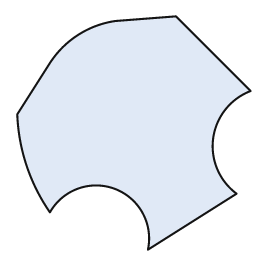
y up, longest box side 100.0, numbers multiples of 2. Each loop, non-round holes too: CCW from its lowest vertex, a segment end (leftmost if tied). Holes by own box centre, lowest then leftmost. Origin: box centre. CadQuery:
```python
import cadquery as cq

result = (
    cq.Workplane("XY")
    .moveTo(6.0, -50.0)
    .lineTo(44.0, -26.0)
    .threePointArc((34.0, -2.0), (50.0, 18.0))
    .lineTo(18.0, 50.0)
    .lineTo(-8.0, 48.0)
    .threePointArc((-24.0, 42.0), (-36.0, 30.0))
    .lineTo(-50.0, 8.0)
    .threePointArc((-46.0, -14.0), (-36.0, -34.0))
    .threePointArc((-8.0, -24.0), (6.0, -50.0))
    .close()
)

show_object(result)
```